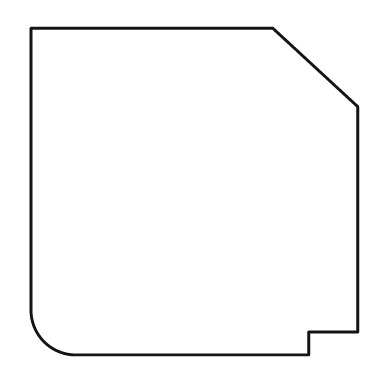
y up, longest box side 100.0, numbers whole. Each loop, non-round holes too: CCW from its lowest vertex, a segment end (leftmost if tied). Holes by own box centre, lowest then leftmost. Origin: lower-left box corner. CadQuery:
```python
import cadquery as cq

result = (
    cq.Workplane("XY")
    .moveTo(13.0, 0.0)
    .lineTo(85.0, 0.0)
    .lineTo(85.0, 7.0)
    .lineTo(100.0, 7.0)
    .lineTo(100.0, 76.0)
    .lineTo(74.0, 100.0)
    .lineTo(0.0, 100.0)
    .lineTo(0.0, 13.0)
    .threePointArc((4.0, 4.0), (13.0, 0.0))
    .close()
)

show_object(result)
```